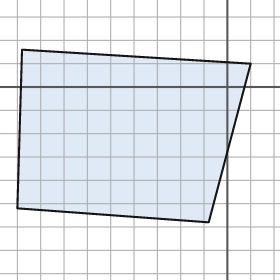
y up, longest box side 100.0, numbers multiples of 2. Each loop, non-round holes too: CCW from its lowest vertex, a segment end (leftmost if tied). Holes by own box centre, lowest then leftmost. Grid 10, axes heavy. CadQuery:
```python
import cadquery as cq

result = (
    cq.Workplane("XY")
    .moveTo(-8.0, -58.0)
    .lineTo(10.0, 10.0)
    .lineTo(-88.0, 16.0)
    .lineTo(-90.0, -52.0)
    .close()
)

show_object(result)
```